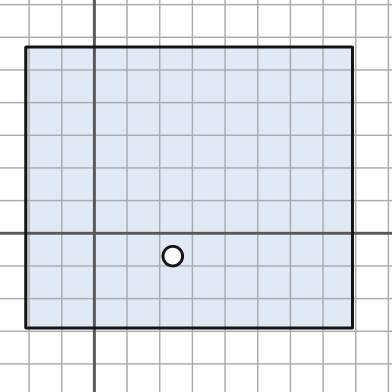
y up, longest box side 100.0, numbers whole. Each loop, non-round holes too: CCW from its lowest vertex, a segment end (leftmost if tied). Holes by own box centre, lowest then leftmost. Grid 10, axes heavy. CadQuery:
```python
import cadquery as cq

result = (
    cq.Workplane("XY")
    .moveTo(-21.0, -29.0)
    .lineTo(79.0, -29.0)
    .lineTo(79.0, 57.0)
    .lineTo(-21.0, 57.0)
    .close()
    .moveTo(24.0, -7.0)
    .circle(3.0)
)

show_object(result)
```